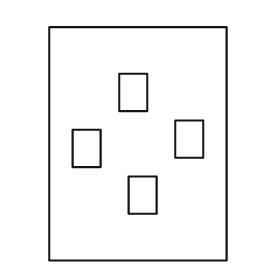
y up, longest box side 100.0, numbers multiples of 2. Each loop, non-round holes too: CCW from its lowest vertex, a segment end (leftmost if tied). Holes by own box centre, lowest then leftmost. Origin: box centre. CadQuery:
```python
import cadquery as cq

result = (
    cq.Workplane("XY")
    .moveTo(-38.0, -50.0)
    .lineTo(38.0, -50.0)
    .lineTo(38.0, 50.0)
    .lineTo(-38.0, 50.0)
    .close()
    .moveTo(-4.0, -30.0)
    .lineTo(8.0, -30.0)
    .lineTo(8.0, -14.0)
    .lineTo(-4.0, -14.0)
    .close()
    .moveTo(-28.0, -10.0)
    .lineTo(-16.0, -10.0)
    .lineTo(-16.0, 6.0)
    .lineTo(-28.0, 6.0)
    .close()
    .moveTo(16.0, -6.0)
    .lineTo(28.0, -6.0)
    .lineTo(28.0, 10.0)
    .lineTo(16.0, 10.0)
    .close()
    .moveTo(-8.0, 14.0)
    .lineTo(4.0, 14.0)
    .lineTo(4.0, 30.0)
    .lineTo(-8.0, 30.0)
    .close()
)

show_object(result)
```